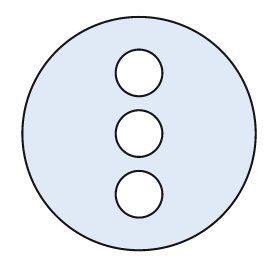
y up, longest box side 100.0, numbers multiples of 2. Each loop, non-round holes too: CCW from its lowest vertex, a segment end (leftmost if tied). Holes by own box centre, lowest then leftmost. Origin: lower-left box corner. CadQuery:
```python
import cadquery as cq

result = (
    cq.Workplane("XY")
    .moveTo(50.0, 50.0)
    .circle(50.0)
    .moveTo(50.0, 24.0)
    .circle(10.0)
    .moveTo(50.0, 50.0)
    .circle(10.0)
    .moveTo(50.0, 76.0)
    .circle(10.0)
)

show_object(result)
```